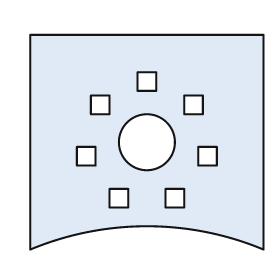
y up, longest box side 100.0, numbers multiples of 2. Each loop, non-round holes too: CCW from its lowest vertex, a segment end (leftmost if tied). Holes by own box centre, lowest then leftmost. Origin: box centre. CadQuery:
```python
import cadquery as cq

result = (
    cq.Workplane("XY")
    .moveTo(-50.0, -46.0)
    .threePointArc((0.0, -36.0), (50.0, -46.0))
    .lineTo(50.0, 46.0)
    .lineTo(-50.0, 46.0)
    .close()
    .moveTo(-16.0, -28.0)
    .lineTo(-8.0, -28.0)
    .lineTo(-8.0, -20.0)
    .lineTo(-16.0, -20.0)
    .close()
    .moveTo(8.0, -28.0)
    .lineTo(16.0, -28.0)
    .lineTo(16.0, -20.0)
    .lineTo(8.0, -20.0)
    .close()
    .moveTo(-30.0, -10.0)
    .lineTo(-22.0, -10.0)
    .lineTo(-22.0, -2.0)
    .lineTo(-30.0, -2.0)
    .close()
    .moveTo(22.0, -10.0)
    .lineTo(30.0, -10.0)
    .lineTo(30.0, -2.0)
    .lineTo(22.0, -2.0)
    .close()
    .moveTo(0.0, 0.0)
    .circle(12.0)
    .moveTo(-24.0, 12.0)
    .lineTo(-16.0, 12.0)
    .lineTo(-16.0, 20.0)
    .lineTo(-24.0, 20.0)
    .close()
    .moveTo(16.0, 12.0)
    .lineTo(24.0, 12.0)
    .lineTo(24.0, 20.0)
    .lineTo(16.0, 20.0)
    .close()
    .moveTo(-4.0, 22.0)
    .lineTo(4.0, 22.0)
    .lineTo(4.0, 30.0)
    .lineTo(-4.0, 30.0)
    .close()
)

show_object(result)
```